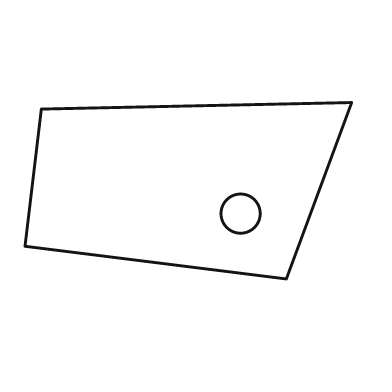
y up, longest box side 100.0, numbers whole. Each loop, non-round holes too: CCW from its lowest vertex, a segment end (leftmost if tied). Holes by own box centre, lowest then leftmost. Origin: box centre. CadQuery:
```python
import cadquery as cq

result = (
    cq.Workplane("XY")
    .moveTo(30.0, -27.0)
    .lineTo(50.0, 27.0)
    .lineTo(-45.0, 25.0)
    .lineTo(-50.0, -17.0)
    .close()
    .moveTo(16.0, -7.0)
    .circle(6.0)
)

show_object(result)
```